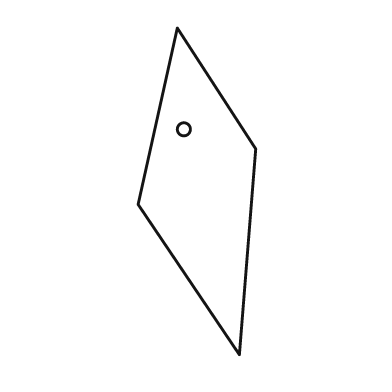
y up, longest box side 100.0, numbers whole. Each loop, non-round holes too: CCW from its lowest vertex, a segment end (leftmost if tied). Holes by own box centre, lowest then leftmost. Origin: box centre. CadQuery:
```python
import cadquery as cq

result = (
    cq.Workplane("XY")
    .moveTo(13.0, -50.0)
    .lineTo(18.0, 13.0)
    .lineTo(-6.0, 50.0)
    .lineTo(-18.0, -4.0)
    .close()
    .moveTo(-4.0, 19.0)
    .circle(2.0)
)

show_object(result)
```